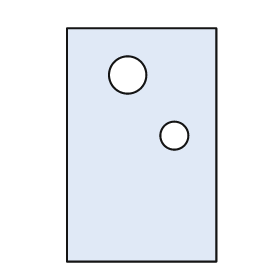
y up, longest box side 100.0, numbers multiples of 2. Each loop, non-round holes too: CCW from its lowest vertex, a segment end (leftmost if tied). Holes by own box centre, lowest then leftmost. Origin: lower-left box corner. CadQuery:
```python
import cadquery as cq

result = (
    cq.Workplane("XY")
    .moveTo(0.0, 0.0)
    .lineTo(64.0, 0.0)
    .lineTo(64.0, 100.0)
    .lineTo(0.0, 100.0)
    .close()
    .moveTo(46.0, 54.0)
    .circle(6.0)
    .moveTo(26.0, 80.0)
    .circle(8.0)
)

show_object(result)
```